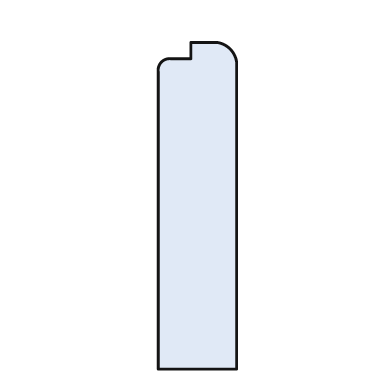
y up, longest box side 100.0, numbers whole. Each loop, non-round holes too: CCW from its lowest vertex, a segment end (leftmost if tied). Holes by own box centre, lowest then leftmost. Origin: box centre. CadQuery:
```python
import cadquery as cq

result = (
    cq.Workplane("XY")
    .moveTo(-12.0, -50.0)
    .lineTo(12.0, -50.0)
    .lineTo(12.0, 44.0)
    .threePointArc((10.0, 48.0), (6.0, 50.0))
    .lineTo(-2.0, 50.0)
    .lineTo(-2.0, 45.0)
    .lineTo(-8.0, 45.0)
    .threePointArc((-11.0, 44.0), (-12.0, 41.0))
    .close()
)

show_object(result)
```